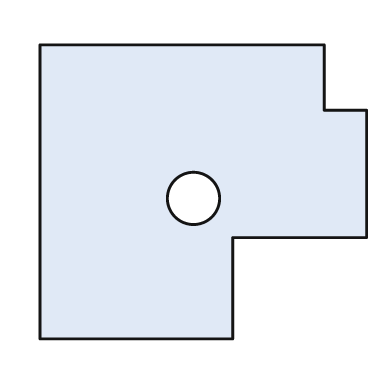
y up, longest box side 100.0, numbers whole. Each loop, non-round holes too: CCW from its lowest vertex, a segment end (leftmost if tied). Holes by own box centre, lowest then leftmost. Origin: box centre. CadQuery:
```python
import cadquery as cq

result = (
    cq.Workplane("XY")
    .moveTo(-50.0, -45.0)
    .lineTo(9.0, -45.0)
    .lineTo(9.0, -14.0)
    .lineTo(50.0, -14.0)
    .lineTo(50.0, 25.0)
    .lineTo(37.0, 25.0)
    .lineTo(37.0, 45.0)
    .lineTo(-50.0, 45.0)
    .close()
    .moveTo(-3.0, -2.0)
    .circle(8.0)
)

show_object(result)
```